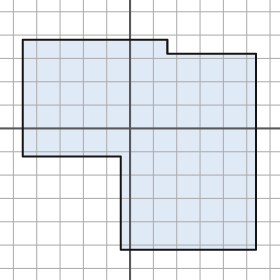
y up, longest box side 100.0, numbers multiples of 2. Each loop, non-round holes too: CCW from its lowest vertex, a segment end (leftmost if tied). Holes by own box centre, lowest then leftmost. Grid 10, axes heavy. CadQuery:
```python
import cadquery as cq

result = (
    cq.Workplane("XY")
    .moveTo(-4.0, -52.0)
    .lineTo(54.0, -52.0)
    .lineTo(54.0, 32.0)
    .lineTo(16.0, 32.0)
    .lineTo(16.0, 38.0)
    .lineTo(-46.0, 38.0)
    .lineTo(-46.0, -12.0)
    .lineTo(-4.0, -12.0)
    .close()
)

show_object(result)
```